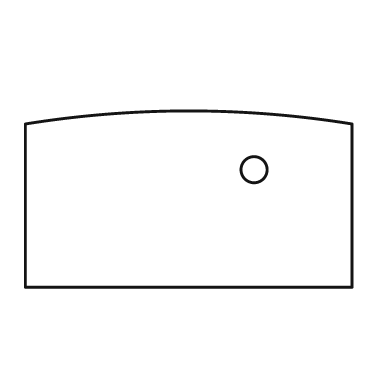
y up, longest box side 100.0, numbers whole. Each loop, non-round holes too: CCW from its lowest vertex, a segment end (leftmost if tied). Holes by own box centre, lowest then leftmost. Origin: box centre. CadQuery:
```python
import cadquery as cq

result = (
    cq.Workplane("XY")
    .moveTo(-50.0, -27.0)
    .lineTo(50.0, -27.0)
    .lineTo(50.0, 23.0)
    .threePointArc((0.0, 27.0), (-50.0, 23.0))
    .close()
    .moveTo(20.0, 9.0)
    .circle(4.0)
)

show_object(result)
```